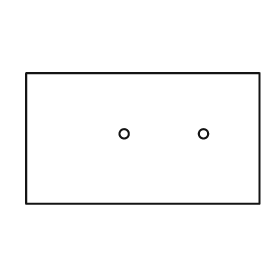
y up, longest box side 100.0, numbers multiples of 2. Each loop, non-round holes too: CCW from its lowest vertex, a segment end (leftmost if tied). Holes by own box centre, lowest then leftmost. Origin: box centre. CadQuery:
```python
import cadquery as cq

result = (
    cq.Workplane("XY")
    .moveTo(-50.0, -28.0)
    .lineTo(50.0, -28.0)
    .lineTo(50.0, 28.0)
    .lineTo(-50.0, 28.0)
    .close()
    .moveTo(-8.0, 2.0)
    .circle(2.0)
    .moveTo(26.0, 2.0)
    .circle(2.0)
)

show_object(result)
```